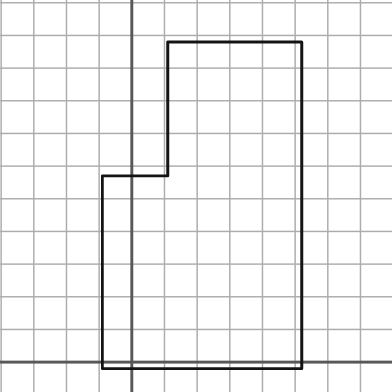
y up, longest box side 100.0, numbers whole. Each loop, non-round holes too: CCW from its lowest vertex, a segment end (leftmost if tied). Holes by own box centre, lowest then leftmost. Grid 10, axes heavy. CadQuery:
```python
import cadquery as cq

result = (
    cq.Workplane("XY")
    .moveTo(-9.0, -2.0)
    .lineTo(52.0, -2.0)
    .lineTo(52.0, 98.0)
    .lineTo(11.0, 98.0)
    .lineTo(11.0, 57.0)
    .lineTo(-9.0, 57.0)
    .close()
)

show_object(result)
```